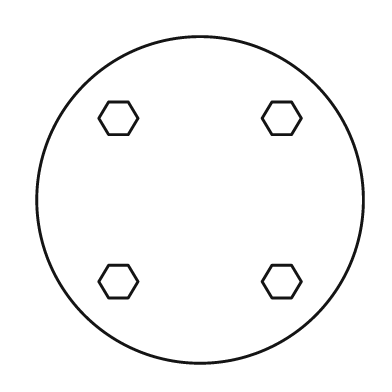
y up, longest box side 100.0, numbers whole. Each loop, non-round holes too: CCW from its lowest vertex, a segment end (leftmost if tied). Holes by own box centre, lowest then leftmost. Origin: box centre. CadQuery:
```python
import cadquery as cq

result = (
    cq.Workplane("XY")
    .moveTo(0.0, 0.0)
    .circle(50.0)
    .moveTo(-28.0, -30.0)
    .lineTo(-22.0, -30.0)
    .lineTo(-19.0, -25.0)
    .lineTo(-22.0, -20.0)
    .lineTo(-28.0, -20.0)
    .lineTo(-31.0, -25.0)
    .close()
    .moveTo(22.0, -30.0)
    .lineTo(28.0, -30.0)
    .lineTo(31.0, -25.0)
    .lineTo(28.0, -20.0)
    .lineTo(22.0, -20.0)
    .lineTo(19.0, -25.0)
    .close()
    .moveTo(-28.0, 20.0)
    .lineTo(-22.0, 20.0)
    .lineTo(-19.0, 25.0)
    .lineTo(-22.0, 30.0)
    .lineTo(-28.0, 30.0)
    .lineTo(-31.0, 25.0)
    .close()
    .moveTo(22.0, 20.0)
    .lineTo(28.0, 20.0)
    .lineTo(31.0, 25.0)
    .lineTo(28.0, 30.0)
    .lineTo(22.0, 30.0)
    .lineTo(19.0, 25.0)
    .close()
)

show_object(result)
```